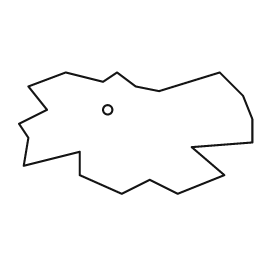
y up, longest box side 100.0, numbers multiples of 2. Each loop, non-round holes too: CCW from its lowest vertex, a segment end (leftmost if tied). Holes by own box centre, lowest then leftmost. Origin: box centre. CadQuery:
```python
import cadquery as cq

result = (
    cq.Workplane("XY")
    .moveTo(-6.0, -26.0)
    .lineTo(6.0, -20.0)
    .lineTo(18.0, -26.0)
    .lineTo(38.0, -18.0)
    .lineTo(24.0, -6.0)
    .lineTo(50.0, -4.0)
    .lineTo(50.0, 6.0)
    .lineTo(46.0, 16.0)
    .lineTo(36.0, 26.0)
    .lineTo(10.0, 18.0)
    .lineTo(0.0, 20.0)
    .lineTo(-8.0, 26.0)
    .lineTo(-14.0, 22.0)
    .lineTo(-30.0, 26.0)
    .lineTo(-46.0, 20.0)
    .lineTo(-38.0, 10.0)
    .lineTo(-50.0, 4.0)
    .lineTo(-46.0, -2.0)
    .lineTo(-48.0, -14.0)
    .lineTo(-24.0, -8.0)
    .lineTo(-24.0, -18.0)
    .close()
    .moveTo(-12.0, 10.0)
    .circle(2.0)
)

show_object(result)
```